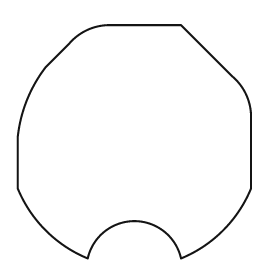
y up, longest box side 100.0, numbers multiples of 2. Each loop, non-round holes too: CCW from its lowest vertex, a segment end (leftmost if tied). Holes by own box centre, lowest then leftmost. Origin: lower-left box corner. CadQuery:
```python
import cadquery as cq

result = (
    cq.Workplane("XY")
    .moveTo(30.0, 0.0)
    .threePointArc((50.0, 16.0), (70.0, 0.0))
    .threePointArc((88.0, 12.0), (100.0, 30.0))
    .lineTo(100.0, 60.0)
    .threePointArc((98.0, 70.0), (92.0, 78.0))
    .lineTo(70.0, 100.0)
    .lineTo(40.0, 100.0)
    .threePointArc((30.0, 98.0), (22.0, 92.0))
    .lineTo(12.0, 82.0)
    .threePointArc((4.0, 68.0), (0.0, 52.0))
    .lineTo(0.0, 30.0)
    .threePointArc((12.0, 12.0), (30.0, 0.0))
    .close()
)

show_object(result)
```